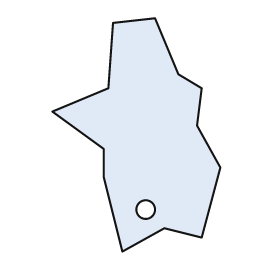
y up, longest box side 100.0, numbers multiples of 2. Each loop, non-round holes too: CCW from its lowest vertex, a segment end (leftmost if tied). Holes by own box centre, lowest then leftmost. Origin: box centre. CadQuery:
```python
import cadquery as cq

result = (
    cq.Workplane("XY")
    .moveTo(-6.0, -50.0)
    .lineTo(12.0, -40.0)
    .lineTo(28.0, -44.0)
    .lineTo(36.0, -14.0)
    .lineTo(26.0, 4.0)
    .lineTo(28.0, 20.0)
    .lineTo(18.0, 26.0)
    .lineTo(8.0, 50.0)
    .lineTo(-10.0, 48.0)
    .lineTo(-12.0, 20.0)
    .lineTo(-36.0, 10.0)
    .lineTo(-14.0, -6.0)
    .lineTo(-14.0, -18.0)
    .close()
    .moveTo(4.0, -32.0)
    .circle(4.0)
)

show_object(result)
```